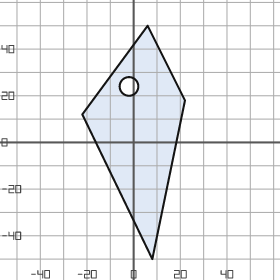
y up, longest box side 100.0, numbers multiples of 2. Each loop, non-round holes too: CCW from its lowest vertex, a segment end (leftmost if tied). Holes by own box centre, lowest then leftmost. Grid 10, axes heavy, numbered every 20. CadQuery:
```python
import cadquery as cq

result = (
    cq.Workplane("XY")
    .moveTo(8.0, -50.0)
    .lineTo(22.0, 18.0)
    .lineTo(6.0, 50.0)
    .lineTo(-22.0, 12.0)
    .close()
    .moveTo(-2.0, 24.0)
    .circle(4.0)
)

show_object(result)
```